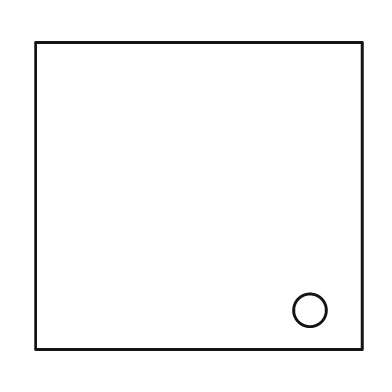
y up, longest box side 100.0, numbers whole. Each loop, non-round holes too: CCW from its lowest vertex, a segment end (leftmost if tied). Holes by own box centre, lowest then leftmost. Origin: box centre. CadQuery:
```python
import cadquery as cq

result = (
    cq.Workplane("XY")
    .moveTo(-50.0, -47.0)
    .lineTo(50.0, -47.0)
    .lineTo(50.0, 47.0)
    .lineTo(-50.0, 47.0)
    .close()
    .moveTo(34.0, -35.0)
    .circle(5.0)
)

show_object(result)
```